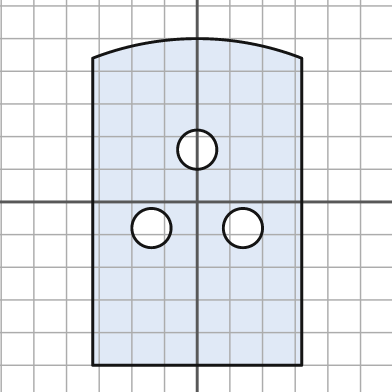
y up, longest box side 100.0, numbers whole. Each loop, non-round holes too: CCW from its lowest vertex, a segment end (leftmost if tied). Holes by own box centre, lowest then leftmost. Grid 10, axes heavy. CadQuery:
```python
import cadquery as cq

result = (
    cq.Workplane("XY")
    .moveTo(-32.0, -50.0)
    .lineTo(32.0, -50.0)
    .lineTo(32.0, 44.0)
    .threePointArc((0.0, 50.0), (-32.0, 44.0))
    .close()
    .moveTo(-14.0, -8.0)
    .circle(6.0)
    .moveTo(14.0, -8.0)
    .circle(6.0)
    .moveTo(0.0, 16.0)
    .circle(6.0)
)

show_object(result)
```